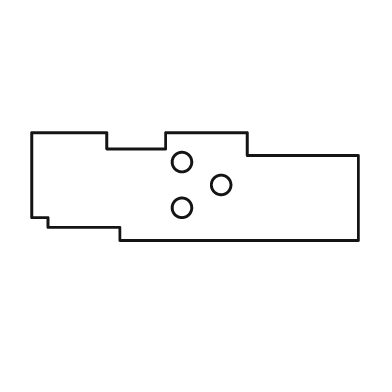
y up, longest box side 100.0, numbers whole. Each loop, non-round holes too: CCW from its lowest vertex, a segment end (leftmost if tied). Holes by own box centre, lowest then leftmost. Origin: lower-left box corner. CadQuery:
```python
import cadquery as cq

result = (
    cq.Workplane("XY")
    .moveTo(27.0, 0.0)
    .lineTo(100.0, 0.0)
    .lineTo(100.0, 26.0)
    .lineTo(66.0, 26.0)
    .lineTo(66.0, 33.0)
    .lineTo(41.0, 33.0)
    .lineTo(41.0, 28.0)
    .lineTo(23.0, 28.0)
    .lineTo(23.0, 33.0)
    .lineTo(0.0, 33.0)
    .lineTo(0.0, 7.0)
    .lineTo(5.0, 7.0)
    .lineTo(5.0, 4.0)
    .lineTo(27.0, 4.0)
    .close()
    .moveTo(46.0, 10.0)
    .circle(3.0)
    .moveTo(58.0, 17.0)
    .circle(3.0)
    .moveTo(46.0, 24.0)
    .circle(3.0)
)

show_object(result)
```